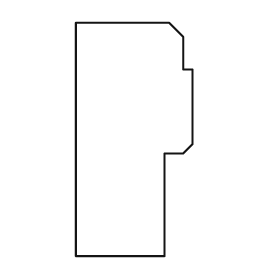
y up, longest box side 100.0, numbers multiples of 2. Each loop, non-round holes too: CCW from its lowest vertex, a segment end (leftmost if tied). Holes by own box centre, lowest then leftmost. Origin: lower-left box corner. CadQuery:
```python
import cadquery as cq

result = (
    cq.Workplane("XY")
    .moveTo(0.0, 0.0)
    .lineTo(38.0, 0.0)
    .lineTo(38.0, 44.0)
    .lineTo(46.0, 44.0)
    .lineTo(50.0, 48.0)
    .lineTo(50.0, 80.0)
    .lineTo(46.0, 80.0)
    .lineTo(46.0, 94.0)
    .lineTo(40.0, 100.0)
    .lineTo(0.0, 100.0)
    .close()
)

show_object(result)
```